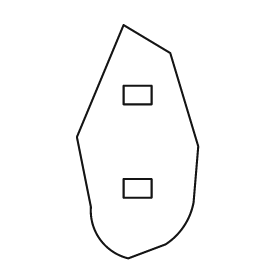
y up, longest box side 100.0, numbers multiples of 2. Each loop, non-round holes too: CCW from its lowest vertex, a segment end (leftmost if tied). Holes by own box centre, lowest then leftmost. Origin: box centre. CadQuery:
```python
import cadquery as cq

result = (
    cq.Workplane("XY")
    .moveTo(-4.0, -50.0)
    .lineTo(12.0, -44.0)
    .threePointArc((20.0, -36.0), (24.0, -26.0))
    .lineTo(26.0, -2.0)
    .lineTo(14.0, 38.0)
    .lineTo(-6.0, 50.0)
    .lineTo(-26.0, 2.0)
    .lineTo(-20.0, -28.0)
    .threePointArc((-16.0, -42.0), (-4.0, -50.0))
    .close()
    .moveTo(-6.0, -24.0)
    .lineTo(6.0, -24.0)
    .lineTo(6.0, -16.0)
    .lineTo(-6.0, -16.0)
    .close()
    .moveTo(-6.0, 16.0)
    .lineTo(6.0, 16.0)
    .lineTo(6.0, 24.0)
    .lineTo(-6.0, 24.0)
    .close()
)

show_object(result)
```